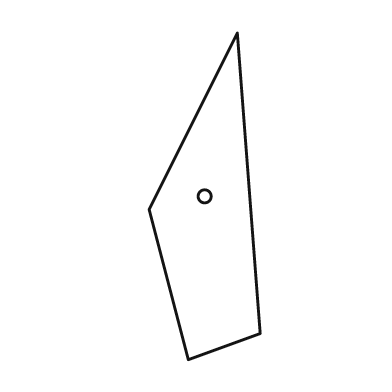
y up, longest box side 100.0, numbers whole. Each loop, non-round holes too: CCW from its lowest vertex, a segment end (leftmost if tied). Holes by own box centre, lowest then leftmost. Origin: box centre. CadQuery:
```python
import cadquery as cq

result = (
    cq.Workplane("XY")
    .moveTo(-5.0, -50.0)
    .lineTo(17.0, -42.0)
    .lineTo(10.0, 50.0)
    .lineTo(-17.0, -4.0)
    .close()
    .moveTo(0.0, 0.0)
    .circle(2.0)
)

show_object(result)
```